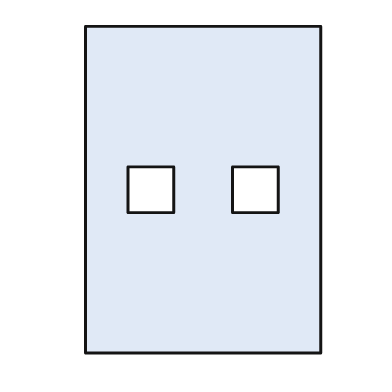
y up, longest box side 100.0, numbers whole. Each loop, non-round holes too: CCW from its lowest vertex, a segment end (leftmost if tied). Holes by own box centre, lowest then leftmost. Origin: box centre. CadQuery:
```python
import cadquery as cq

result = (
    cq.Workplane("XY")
    .moveTo(-36.0, -50.0)
    .lineTo(36.0, -50.0)
    .lineTo(36.0, 50.0)
    .lineTo(-36.0, 50.0)
    .close()
    .moveTo(-23.0, -7.0)
    .lineTo(-9.0, -7.0)
    .lineTo(-9.0, 7.0)
    .lineTo(-23.0, 7.0)
    .close()
    .moveTo(9.0, -7.0)
    .lineTo(23.0, -7.0)
    .lineTo(23.0, 7.0)
    .lineTo(9.0, 7.0)
    .close()
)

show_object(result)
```